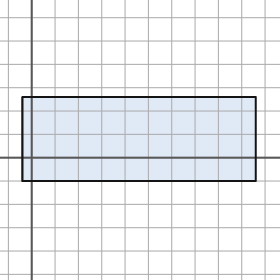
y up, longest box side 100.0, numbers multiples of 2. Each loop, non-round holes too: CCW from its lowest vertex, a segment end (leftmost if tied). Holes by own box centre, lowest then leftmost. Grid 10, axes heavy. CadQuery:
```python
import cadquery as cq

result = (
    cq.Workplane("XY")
    .moveTo(-4.0, -10.0)
    .lineTo(96.0, -10.0)
    .lineTo(96.0, 26.0)
    .lineTo(-4.0, 26.0)
    .close()
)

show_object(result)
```